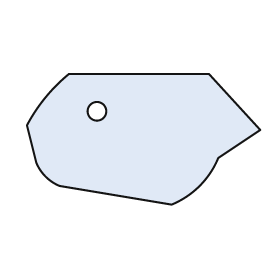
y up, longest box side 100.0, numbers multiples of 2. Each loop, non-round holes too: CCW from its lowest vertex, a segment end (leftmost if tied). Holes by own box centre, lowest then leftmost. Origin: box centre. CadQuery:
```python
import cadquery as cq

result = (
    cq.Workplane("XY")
    .moveTo(12.0, -28.0)
    .threePointArc((24.0, -20.0), (32.0, -8.0))
    .lineTo(50.0, 4.0)
    .lineTo(28.0, 28.0)
    .lineTo(-32.0, 28.0)
    .threePointArc((-42.0, 18.0), (-50.0, 6.0))
    .lineTo(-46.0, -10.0)
    .threePointArc((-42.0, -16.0), (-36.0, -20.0))
    .close()
    .moveTo(-20.0, 12.0)
    .circle(4.0)
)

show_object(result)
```